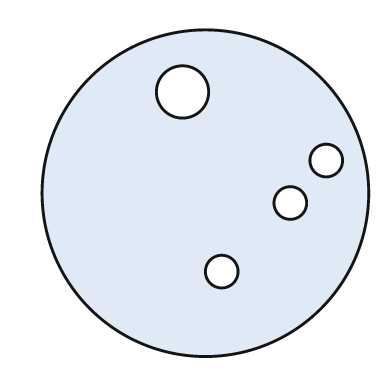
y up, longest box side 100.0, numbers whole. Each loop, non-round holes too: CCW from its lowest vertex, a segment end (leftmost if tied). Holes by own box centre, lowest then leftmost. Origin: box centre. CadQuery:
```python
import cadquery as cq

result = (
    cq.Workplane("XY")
    .moveTo(0.0, 0.0)
    .circle(50.0)
    .moveTo(5.0, -24.0)
    .circle(5.0)
    .moveTo(26.0, -3.0)
    .circle(5.0)
    .moveTo(37.0, 10.0)
    .circle(5.0)
    .moveTo(-7.0, 31.0)
    .circle(8.0)
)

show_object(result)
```